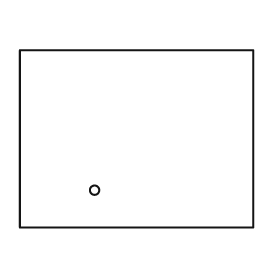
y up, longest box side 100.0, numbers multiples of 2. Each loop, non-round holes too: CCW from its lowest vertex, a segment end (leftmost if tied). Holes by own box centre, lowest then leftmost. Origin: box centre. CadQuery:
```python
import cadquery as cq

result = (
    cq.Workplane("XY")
    .moveTo(-50.0, -38.0)
    .lineTo(50.0, -38.0)
    .lineTo(50.0, 38.0)
    .lineTo(-50.0, 38.0)
    .close()
    .moveTo(-18.0, -22.0)
    .circle(2.0)
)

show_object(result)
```